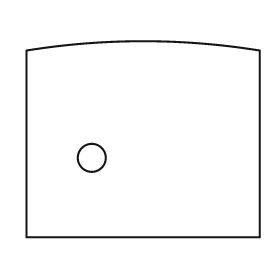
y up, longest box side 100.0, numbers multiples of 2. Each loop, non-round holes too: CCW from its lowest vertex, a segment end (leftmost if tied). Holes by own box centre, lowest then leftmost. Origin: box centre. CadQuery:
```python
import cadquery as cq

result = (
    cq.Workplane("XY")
    .moveTo(-50.0, -42.0)
    .lineTo(50.0, -42.0)
    .lineTo(50.0, 38.0)
    .threePointArc((0.0, 42.0), (-50.0, 38.0))
    .close()
    .moveTo(-22.0, -8.0)
    .circle(6.0)
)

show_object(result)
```